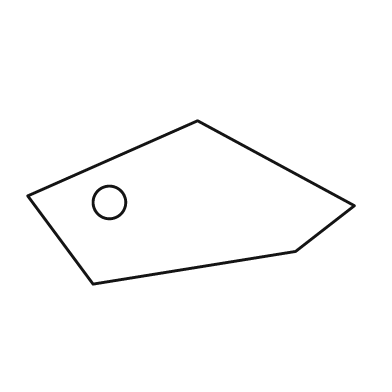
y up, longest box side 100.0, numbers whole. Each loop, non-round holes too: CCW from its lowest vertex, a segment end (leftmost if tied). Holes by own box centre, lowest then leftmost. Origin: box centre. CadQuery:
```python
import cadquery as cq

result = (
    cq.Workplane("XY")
    .moveTo(-30.0, -25.0)
    .lineTo(32.0, -15.0)
    .lineTo(50.0, -1.0)
    .lineTo(2.0, 25.0)
    .lineTo(-50.0, 2.0)
    .close()
    .moveTo(-25.0, 0.0)
    .circle(5.0)
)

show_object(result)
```